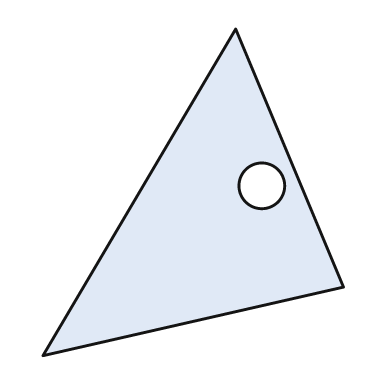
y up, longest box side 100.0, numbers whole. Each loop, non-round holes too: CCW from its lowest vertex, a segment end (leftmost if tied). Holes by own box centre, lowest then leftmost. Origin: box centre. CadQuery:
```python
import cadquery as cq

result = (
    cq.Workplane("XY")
    .moveTo(-46.0, -50.0)
    .lineTo(46.0, -29.0)
    .lineTo(13.0, 50.0)
    .close()
    .moveTo(21.0, 2.0)
    .circle(7.0)
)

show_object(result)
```